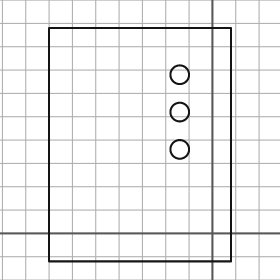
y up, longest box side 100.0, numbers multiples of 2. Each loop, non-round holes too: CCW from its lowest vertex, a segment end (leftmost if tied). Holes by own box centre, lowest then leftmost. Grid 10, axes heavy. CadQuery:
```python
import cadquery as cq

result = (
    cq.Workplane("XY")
    .moveTo(-70.0, -12.0)
    .lineTo(8.0, -12.0)
    .lineTo(8.0, 88.0)
    .lineTo(-70.0, 88.0)
    .close()
    .moveTo(-14.0, 36.0)
    .circle(4.0)
    .moveTo(-14.0, 52.0)
    .circle(4.0)
    .moveTo(-14.0, 68.0)
    .circle(4.0)
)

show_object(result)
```